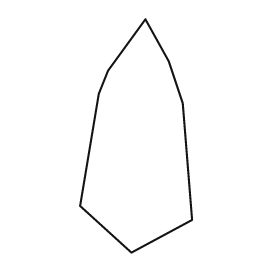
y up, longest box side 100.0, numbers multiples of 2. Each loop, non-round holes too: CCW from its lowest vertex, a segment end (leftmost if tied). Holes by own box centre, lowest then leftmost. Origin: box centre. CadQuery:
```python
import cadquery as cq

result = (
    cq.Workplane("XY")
    .moveTo(-2.0, -50.0)
    .lineTo(24.0, -36.0)
    .lineTo(20.0, 14.0)
    .lineTo(14.0, 32.0)
    .lineTo(4.0, 50.0)
    .lineTo(-12.0, 28.0)
    .lineTo(-16.0, 18.0)
    .lineTo(-24.0, -30.0)
    .close()
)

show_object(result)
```